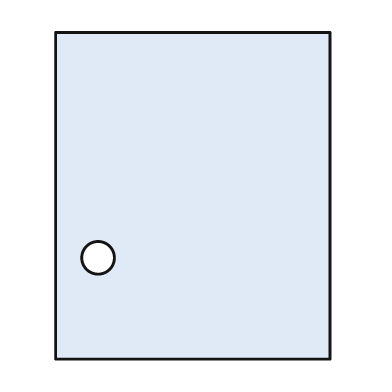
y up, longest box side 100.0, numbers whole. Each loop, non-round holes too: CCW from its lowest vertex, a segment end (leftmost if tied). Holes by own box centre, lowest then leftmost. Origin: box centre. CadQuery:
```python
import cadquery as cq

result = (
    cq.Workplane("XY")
    .moveTo(-42.0, -50.0)
    .lineTo(42.0, -50.0)
    .lineTo(42.0, 50.0)
    .lineTo(-42.0, 50.0)
    .close()
    .moveTo(-29.0, -19.0)
    .circle(5.0)
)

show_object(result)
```